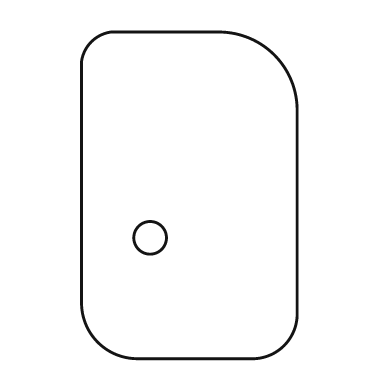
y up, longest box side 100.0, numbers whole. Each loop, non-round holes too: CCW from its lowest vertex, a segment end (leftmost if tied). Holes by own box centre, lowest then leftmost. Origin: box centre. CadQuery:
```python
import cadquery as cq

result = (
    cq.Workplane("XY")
    .moveTo(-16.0, -50.0)
    .lineTo(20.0, -50.0)
    .threePointArc((29.0, -46.0), (33.0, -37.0))
    .lineTo(33.0, 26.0)
    .threePointArc((26.0, 43.0), (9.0, 50.0))
    .lineTo(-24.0, 50.0)
    .threePointArc((-30.0, 47.0), (-33.0, 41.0))
    .lineTo(-33.0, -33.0)
    .threePointArc((-28.0, -45.0), (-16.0, -50.0))
    .close()
    .moveTo(-12.0, -13.0)
    .circle(5.0)
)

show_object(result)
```